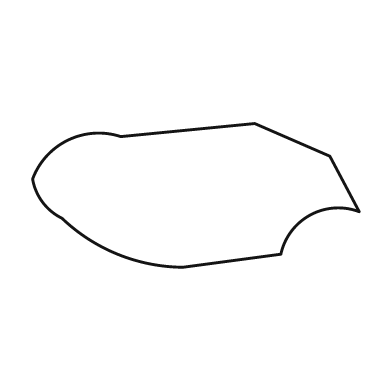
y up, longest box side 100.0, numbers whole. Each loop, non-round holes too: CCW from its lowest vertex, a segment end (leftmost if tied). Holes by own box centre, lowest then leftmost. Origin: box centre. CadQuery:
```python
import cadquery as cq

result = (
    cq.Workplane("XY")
    .moveTo(-4.0, -22.0)
    .lineTo(26.0, -18.0)
    .threePointArc((35.0, -6.0), (50.0, -5.0))
    .lineTo(41.0, 12.0)
    .lineTo(18.0, 22.0)
    .lineTo(-23.0, 18.0)
    .threePointArc((-39.0, 17.0), (-50.0, 5.0))
    .threePointArc((-47.0, -2.0), (-41.0, -7.0))
    .threePointArc((-24.0, -18.0), (-4.0, -22.0))
    .close()
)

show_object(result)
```